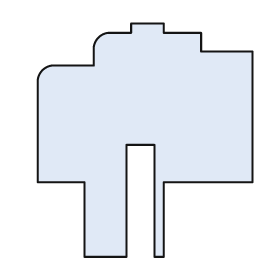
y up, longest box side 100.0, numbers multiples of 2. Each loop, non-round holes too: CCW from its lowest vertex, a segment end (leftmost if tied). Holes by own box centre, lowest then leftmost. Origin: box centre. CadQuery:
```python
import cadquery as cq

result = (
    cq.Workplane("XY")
    .moveTo(-26.0, -50.0)
    .lineTo(-8.0, -50.0)
    .lineTo(-8.0, -2.0)
    .lineTo(4.0, -2.0)
    .lineTo(4.0, -50.0)
    .lineTo(8.0, -50.0)
    .lineTo(8.0, -18.0)
    .lineTo(46.0, -18.0)
    .lineTo(46.0, 38.0)
    .lineTo(24.0, 38.0)
    .lineTo(24.0, 46.0)
    .lineTo(8.0, 46.0)
    .lineTo(8.0, 50.0)
    .lineTo(-6.0, 50.0)
    .lineTo(-6.0, 46.0)
    .lineTo(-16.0, 46.0)
    .threePointArc((-20.0, 44.0), (-22.0, 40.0))
    .lineTo(-22.0, 32.0)
    .lineTo(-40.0, 32.0)
    .threePointArc((-44.0, 30.0), (-46.0, 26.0))
    .lineTo(-46.0, -18.0)
    .lineTo(-26.0, -18.0)
    .close()
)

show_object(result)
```